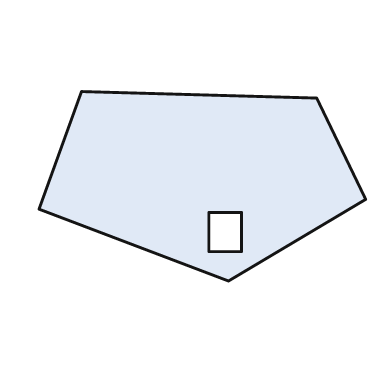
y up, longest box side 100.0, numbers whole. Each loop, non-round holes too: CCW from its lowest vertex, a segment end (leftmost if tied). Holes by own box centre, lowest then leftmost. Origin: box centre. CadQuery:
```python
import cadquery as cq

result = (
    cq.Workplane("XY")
    .moveTo(8.0, -29.0)
    .lineTo(50.0, -4.0)
    .lineTo(35.0, 27.0)
    .lineTo(-37.0, 29.0)
    .lineTo(-50.0, -7.0)
    .close()
    .moveTo(2.0, -20.0)
    .lineTo(12.0, -20.0)
    .lineTo(12.0, -8.0)
    .lineTo(2.0, -8.0)
    .close()
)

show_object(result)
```